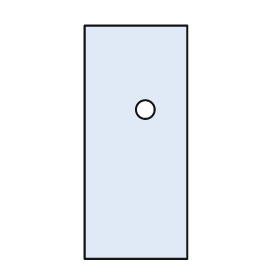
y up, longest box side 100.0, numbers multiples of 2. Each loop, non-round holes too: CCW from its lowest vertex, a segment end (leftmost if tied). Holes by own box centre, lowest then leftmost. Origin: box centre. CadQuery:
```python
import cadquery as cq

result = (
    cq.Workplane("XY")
    .moveTo(-22.0, -50.0)
    .lineTo(22.0, -50.0)
    .lineTo(22.0, 50.0)
    .lineTo(-22.0, 50.0)
    .close()
    .moveTo(4.0, 14.0)
    .circle(4.0)
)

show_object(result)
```